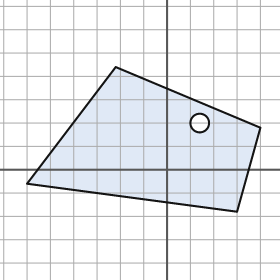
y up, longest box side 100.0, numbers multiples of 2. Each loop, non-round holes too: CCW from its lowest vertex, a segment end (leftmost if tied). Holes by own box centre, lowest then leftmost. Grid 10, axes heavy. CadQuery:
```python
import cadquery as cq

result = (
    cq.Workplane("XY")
    .moveTo(30.0, -18.0)
    .lineTo(40.0, 18.0)
    .lineTo(-22.0, 44.0)
    .lineTo(-60.0, -6.0)
    .close()
    .moveTo(14.0, 20.0)
    .circle(4.0)
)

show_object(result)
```